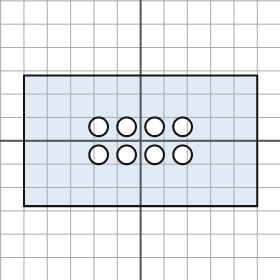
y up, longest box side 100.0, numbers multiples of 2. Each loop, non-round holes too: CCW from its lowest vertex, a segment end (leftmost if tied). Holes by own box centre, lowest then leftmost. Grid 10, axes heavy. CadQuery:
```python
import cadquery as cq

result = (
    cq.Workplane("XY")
    .moveTo(-50.0, -28.0)
    .lineTo(50.0, -28.0)
    .lineTo(50.0, 28.0)
    .lineTo(-50.0, 28.0)
    .close()
    .moveTo(-18.0, -6.0)
    .circle(4.0)
    .moveTo(-6.0, -6.0)
    .circle(4.0)
    .moveTo(6.0, -6.0)
    .circle(4.0)
    .moveTo(18.0, -6.0)
    .circle(4.0)
    .moveTo(-18.0, 6.0)
    .circle(4.0)
    .moveTo(-6.0, 6.0)
    .circle(4.0)
    .moveTo(6.0, 6.0)
    .circle(4.0)
    .moveTo(18.0, 6.0)
    .circle(4.0)
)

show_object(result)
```